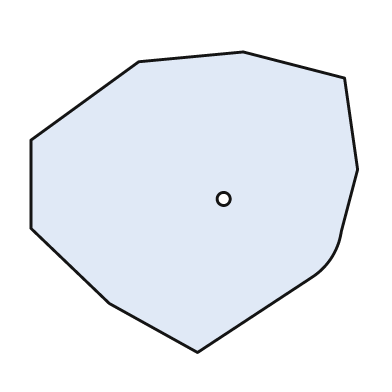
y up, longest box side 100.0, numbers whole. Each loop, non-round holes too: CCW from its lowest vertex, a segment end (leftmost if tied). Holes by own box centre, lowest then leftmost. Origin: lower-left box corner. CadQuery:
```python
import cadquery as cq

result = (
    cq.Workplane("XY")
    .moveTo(51.0, 0.0)
    .lineTo(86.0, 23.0)
    .threePointArc((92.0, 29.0), (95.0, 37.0))
    .lineTo(100.0, 56.0)
    .lineTo(96.0, 84.0)
    .lineTo(65.0, 92.0)
    .lineTo(33.0, 89.0)
    .lineTo(0.0, 65.0)
    .lineTo(0.0, 38.0)
    .lineTo(24.0, 15.0)
    .close()
    .moveTo(59.0, 47.0)
    .circle(2.0)
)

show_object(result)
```